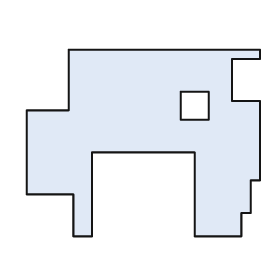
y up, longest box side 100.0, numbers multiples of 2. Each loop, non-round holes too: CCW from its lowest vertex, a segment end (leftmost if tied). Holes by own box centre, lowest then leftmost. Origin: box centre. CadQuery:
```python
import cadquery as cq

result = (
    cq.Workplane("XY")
    .moveTo(-30.0, -40.0)
    .lineTo(-22.0, -40.0)
    .lineTo(-22.0, -4.0)
    .lineTo(22.0, -4.0)
    .lineTo(22.0, -40.0)
    .lineTo(42.0, -40.0)
    .lineTo(42.0, -30.0)
    .lineTo(46.0, -30.0)
    .lineTo(46.0, -16.0)
    .lineTo(50.0, -16.0)
    .lineTo(50.0, 18.0)
    .lineTo(38.0, 18.0)
    .lineTo(38.0, 36.0)
    .lineTo(50.0, 36.0)
    .lineTo(50.0, 40.0)
    .lineTo(-32.0, 40.0)
    .lineTo(-32.0, 14.0)
    .lineTo(-50.0, 14.0)
    .lineTo(-50.0, -22.0)
    .lineTo(-30.0, -22.0)
    .close()
    .moveTo(16.0, 10.0)
    .lineTo(28.0, 10.0)
    .lineTo(28.0, 22.0)
    .lineTo(16.0, 22.0)
    .close()
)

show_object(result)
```